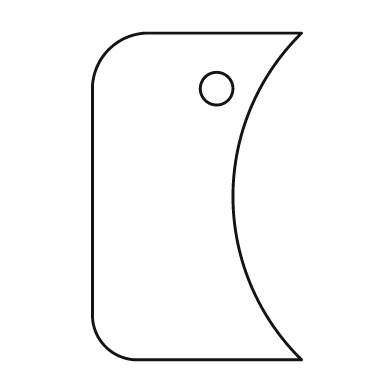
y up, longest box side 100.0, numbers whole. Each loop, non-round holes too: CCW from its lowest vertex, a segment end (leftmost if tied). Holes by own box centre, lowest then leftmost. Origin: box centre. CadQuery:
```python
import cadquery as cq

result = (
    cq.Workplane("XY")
    .moveTo(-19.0, -50.0)
    .lineTo(32.0, -50.0)
    .threePointArc((11.0, 0.0), (32.0, 50.0))
    .lineTo(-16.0, 50.0)
    .threePointArc((-27.0, 45.0), (-32.0, 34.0))
    .lineTo(-32.0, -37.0)
    .threePointArc((-28.0, -46.0), (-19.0, -50.0))
    .close()
    .moveTo(6.0, 33.0)
    .circle(5.0)
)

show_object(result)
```